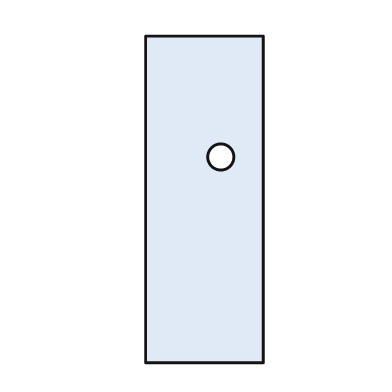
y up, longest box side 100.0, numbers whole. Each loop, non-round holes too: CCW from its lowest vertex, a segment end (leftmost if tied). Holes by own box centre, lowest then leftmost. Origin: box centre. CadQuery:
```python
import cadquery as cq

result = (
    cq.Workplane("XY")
    .moveTo(-18.0, -50.0)
    .lineTo(18.0, -50.0)
    .lineTo(18.0, 50.0)
    .lineTo(-18.0, 50.0)
    .close()
    .moveTo(5.0, 13.0)
    .circle(4.0)
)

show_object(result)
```